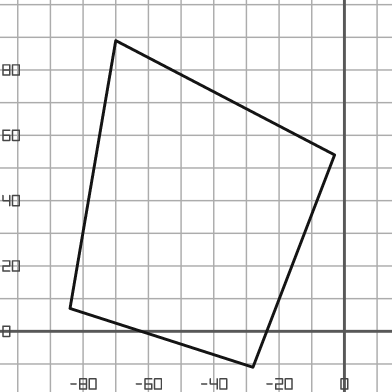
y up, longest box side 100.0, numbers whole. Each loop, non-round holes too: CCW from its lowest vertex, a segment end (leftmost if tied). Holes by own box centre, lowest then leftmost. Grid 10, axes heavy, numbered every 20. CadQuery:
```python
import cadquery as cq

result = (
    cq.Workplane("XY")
    .moveTo(-28.0, -11.0)
    .lineTo(-3.0, 54.0)
    .lineTo(-70.0, 89.0)
    .lineTo(-84.0, 7.0)
    .close()
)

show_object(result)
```